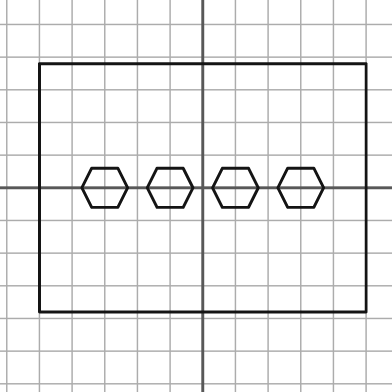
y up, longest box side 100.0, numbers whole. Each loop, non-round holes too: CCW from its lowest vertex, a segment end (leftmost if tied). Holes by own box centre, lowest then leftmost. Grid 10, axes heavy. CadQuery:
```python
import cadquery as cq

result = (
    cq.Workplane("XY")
    .moveTo(-50.0, -38.0)
    .lineTo(50.0, -38.0)
    .lineTo(50.0, 38.0)
    .lineTo(-50.0, 38.0)
    .close()
    .moveTo(-34.0, -6.0)
    .lineTo(-26.0, -6.0)
    .lineTo(-23.0, 0.0)
    .lineTo(-26.0, 6.0)
    .lineTo(-34.0, 6.0)
    .lineTo(-37.0, 0.0)
    .close()
    .moveTo(-14.0, -6.0)
    .lineTo(-6.0, -6.0)
    .lineTo(-3.0, 0.0)
    .lineTo(-6.0, 6.0)
    .lineTo(-14.0, 6.0)
    .lineTo(-17.0, 0.0)
    .close()
    .moveTo(6.0, -6.0)
    .lineTo(14.0, -6.0)
    .lineTo(17.0, 0.0)
    .lineTo(14.0, 6.0)
    .lineTo(6.0, 6.0)
    .lineTo(3.0, 0.0)
    .close()
    .moveTo(26.0, -6.0)
    .lineTo(34.0, -6.0)
    .lineTo(37.0, 0.0)
    .lineTo(34.0, 6.0)
    .lineTo(26.0, 6.0)
    .lineTo(23.0, 0.0)
    .close()
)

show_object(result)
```